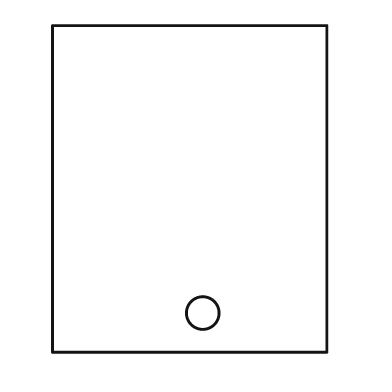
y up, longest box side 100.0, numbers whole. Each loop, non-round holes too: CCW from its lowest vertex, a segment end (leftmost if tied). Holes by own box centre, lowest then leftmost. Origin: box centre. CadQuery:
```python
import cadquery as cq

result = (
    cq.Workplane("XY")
    .moveTo(-42.0, -50.0)
    .lineTo(42.0, -50.0)
    .lineTo(42.0, 50.0)
    .lineTo(-42.0, 50.0)
    .close()
    .moveTo(4.0, -38.0)
    .circle(5.0)
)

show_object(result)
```